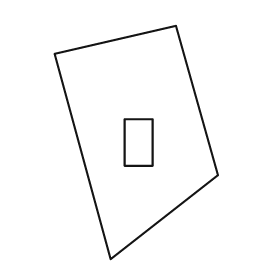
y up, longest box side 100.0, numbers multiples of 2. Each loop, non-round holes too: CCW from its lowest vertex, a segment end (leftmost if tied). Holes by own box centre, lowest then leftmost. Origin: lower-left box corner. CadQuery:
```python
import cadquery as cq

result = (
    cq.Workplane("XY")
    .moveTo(24.0, 0.0)
    .lineTo(70.0, 36.0)
    .lineTo(52.0, 100.0)
    .lineTo(0.0, 88.0)
    .close()
    .moveTo(30.0, 40.0)
    .lineTo(42.0, 40.0)
    .lineTo(42.0, 60.0)
    .lineTo(30.0, 60.0)
    .close()
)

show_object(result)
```